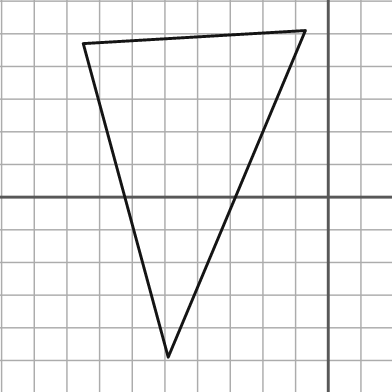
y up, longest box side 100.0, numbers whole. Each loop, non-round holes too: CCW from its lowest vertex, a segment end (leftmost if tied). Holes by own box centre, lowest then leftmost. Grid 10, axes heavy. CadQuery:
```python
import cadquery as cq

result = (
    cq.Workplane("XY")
    .moveTo(-49.0, -49.0)
    .lineTo(-7.0, 51.0)
    .lineTo(-75.0, 47.0)
    .close()
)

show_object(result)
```